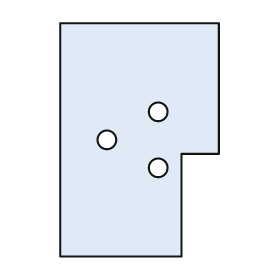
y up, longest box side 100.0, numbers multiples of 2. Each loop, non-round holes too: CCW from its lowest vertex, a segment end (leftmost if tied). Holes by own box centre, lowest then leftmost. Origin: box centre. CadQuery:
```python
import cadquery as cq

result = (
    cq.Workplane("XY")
    .moveTo(-34.0, -50.0)
    .lineTo(18.0, -50.0)
    .lineTo(18.0, -6.0)
    .lineTo(34.0, -6.0)
    .lineTo(34.0, 50.0)
    .lineTo(-34.0, 50.0)
    .close()
    .moveTo(8.0, -12.0)
    .circle(4.0)
    .moveTo(-14.0, 0.0)
    .circle(4.0)
    .moveTo(8.0, 12.0)
    .circle(4.0)
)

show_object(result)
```